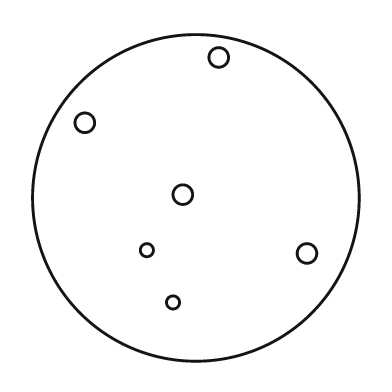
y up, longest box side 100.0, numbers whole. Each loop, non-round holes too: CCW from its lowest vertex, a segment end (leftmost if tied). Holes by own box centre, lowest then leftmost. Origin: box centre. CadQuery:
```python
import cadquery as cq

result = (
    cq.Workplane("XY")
    .moveTo(0.0, 0.0)
    .circle(50.0)
    .moveTo(-7.0, -32.0)
    .circle(2.0)
    .moveTo(34.0, -17.0)
    .circle(3.0)
    .moveTo(-15.0, -16.0)
    .circle(2.0)
    .moveTo(-4.0, 1.0)
    .circle(3.0)
    .moveTo(-34.0, 23.0)
    .circle(3.0)
    .moveTo(7.0, 43.0)
    .circle(3.0)
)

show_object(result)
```